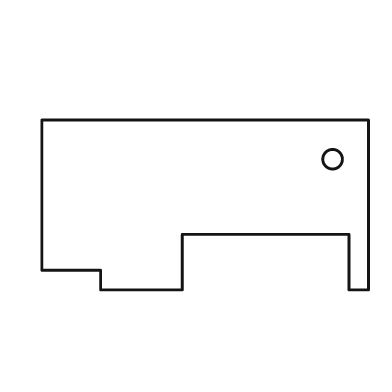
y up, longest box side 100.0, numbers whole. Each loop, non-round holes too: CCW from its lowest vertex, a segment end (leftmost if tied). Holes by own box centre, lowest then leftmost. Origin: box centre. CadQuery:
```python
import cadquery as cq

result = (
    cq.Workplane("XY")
    .moveTo(-32.0, -26.0)
    .lineTo(-7.0, -26.0)
    .lineTo(-7.0, -9.0)
    .lineTo(44.0, -9.0)
    .lineTo(44.0, -26.0)
    .lineTo(50.0, -26.0)
    .lineTo(50.0, 26.0)
    .lineTo(-50.0, 26.0)
    .lineTo(-50.0, -20.0)
    .lineTo(-32.0, -20.0)
    .close()
    .moveTo(39.0, 14.0)
    .circle(3.0)
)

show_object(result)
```